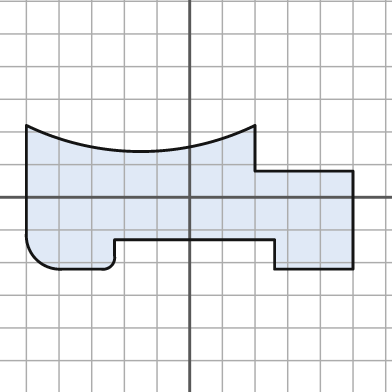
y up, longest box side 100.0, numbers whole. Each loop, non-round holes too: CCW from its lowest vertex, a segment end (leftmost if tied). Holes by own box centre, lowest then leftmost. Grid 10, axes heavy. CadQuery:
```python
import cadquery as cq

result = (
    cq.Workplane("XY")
    .moveTo(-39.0, -22.0)
    .lineTo(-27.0, -22.0)
    .threePointArc((-24.0, -21.0), (-23.0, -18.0))
    .lineTo(-23.0, -13.0)
    .lineTo(26.0, -13.0)
    .lineTo(26.0, -22.0)
    .lineTo(50.0, -22.0)
    .lineTo(50.0, 8.0)
    .lineTo(20.0, 8.0)
    .lineTo(20.0, 22.0)
    .threePointArc((-15.0, 14.0), (-50.0, 22.0))
    .lineTo(-50.0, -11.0)
    .threePointArc((-47.0, -19.0), (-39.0, -22.0))
    .close()
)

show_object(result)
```